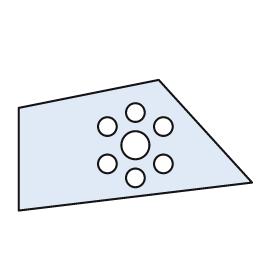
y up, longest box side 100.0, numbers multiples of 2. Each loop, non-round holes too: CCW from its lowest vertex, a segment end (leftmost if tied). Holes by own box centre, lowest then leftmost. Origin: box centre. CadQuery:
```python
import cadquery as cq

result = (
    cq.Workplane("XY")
    .moveTo(-50.0, -28.0)
    .lineTo(50.0, -16.0)
    .lineTo(10.0, 28.0)
    .lineTo(-50.0, 16.0)
    .close()
    .moveTo(0.0, -14.0)
    .circle(4.0)
    .moveTo(-12.0, -8.0)
    .circle(4.0)
    .moveTo(12.0, -8.0)
    .circle(4.0)
    .moveTo(0.0, 0.0)
    .circle(6.0)
    .moveTo(-12.0, 8.0)
    .circle(4.0)
    .moveTo(12.0, 8.0)
    .circle(4.0)
    .moveTo(0.0, 14.0)
    .circle(4.0)
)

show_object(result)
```